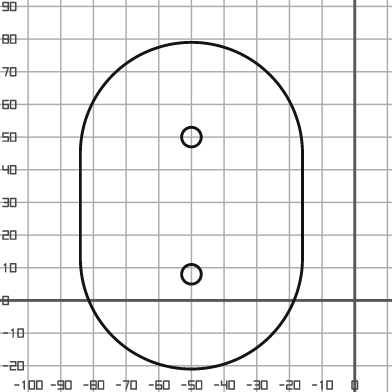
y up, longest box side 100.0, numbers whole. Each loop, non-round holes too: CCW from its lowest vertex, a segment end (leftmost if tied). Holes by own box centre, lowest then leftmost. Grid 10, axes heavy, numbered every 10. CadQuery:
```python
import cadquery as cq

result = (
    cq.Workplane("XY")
    .moveTo(-84.0, 13.0)
    .threePointArc((-50.0, -21.0), (-16.0, 13.0))
    .lineTo(-16.0, 45.0)
    .threePointArc((-50.0, 79.0), (-84.0, 45.0))
    .close()
    .moveTo(-50.0, 8.0)
    .circle(3.0)
    .moveTo(-50.0, 50.0)
    .circle(3.0)
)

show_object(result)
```